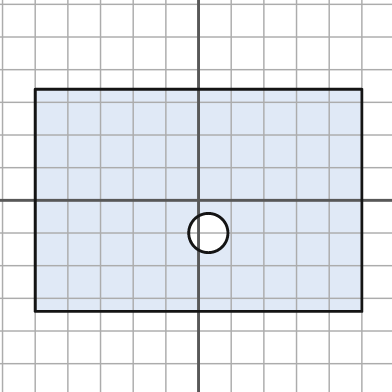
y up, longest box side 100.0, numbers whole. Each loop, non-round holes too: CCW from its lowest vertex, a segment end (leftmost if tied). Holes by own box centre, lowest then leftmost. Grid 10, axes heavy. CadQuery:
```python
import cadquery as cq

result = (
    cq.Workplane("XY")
    .moveTo(-50.0, -34.0)
    .lineTo(50.0, -34.0)
    .lineTo(50.0, 34.0)
    .lineTo(-50.0, 34.0)
    .close()
    .moveTo(3.0, -10.0)
    .circle(6.0)
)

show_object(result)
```